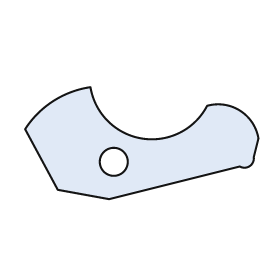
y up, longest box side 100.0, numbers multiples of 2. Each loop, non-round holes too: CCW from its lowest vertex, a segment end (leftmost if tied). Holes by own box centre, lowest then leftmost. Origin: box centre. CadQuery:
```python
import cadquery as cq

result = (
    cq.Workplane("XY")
    .moveTo(-14.0, -24.0)
    .lineTo(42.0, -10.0)
    .threePointArc((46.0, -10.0), (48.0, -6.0))
    .lineTo(50.0, 2.0)
    .threePointArc((42.0, 14.0), (28.0, 16.0))
    .threePointArc((0.0, 2.0), (-22.0, 24.0))
    .threePointArc((-38.0, 18.0), (-50.0, 6.0))
    .lineTo(-36.0, -20.0)
    .close()
    .moveTo(-12.0, -8.0)
    .circle(6.0)
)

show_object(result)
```